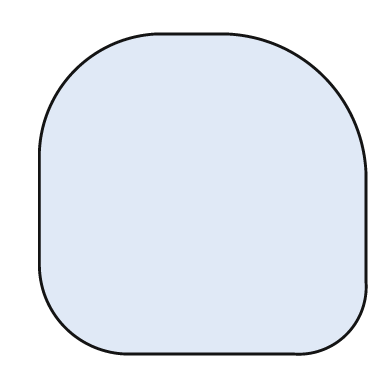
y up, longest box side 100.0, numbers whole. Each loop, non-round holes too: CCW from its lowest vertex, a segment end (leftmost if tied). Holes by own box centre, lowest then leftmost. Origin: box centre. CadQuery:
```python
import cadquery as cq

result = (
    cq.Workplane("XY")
    .moveTo(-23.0, -49.0)
    .lineTo(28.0, -49.0)
    .threePointArc((44.0, -43.0), (50.0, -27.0))
    .lineTo(50.0, 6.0)
    .threePointArc((37.0, 36.0), (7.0, 49.0))
    .lineTo(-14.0, 49.0)
    .threePointArc((-39.0, 38.0), (-50.0, 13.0))
    .lineTo(-50.0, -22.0)
    .threePointArc((-42.0, -41.0), (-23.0, -49.0))
    .close()
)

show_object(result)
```